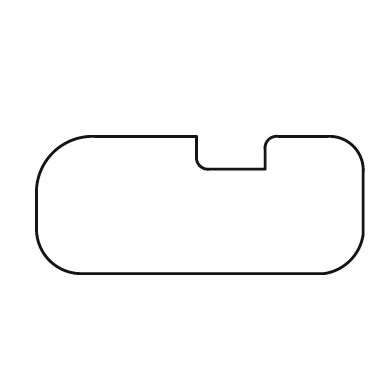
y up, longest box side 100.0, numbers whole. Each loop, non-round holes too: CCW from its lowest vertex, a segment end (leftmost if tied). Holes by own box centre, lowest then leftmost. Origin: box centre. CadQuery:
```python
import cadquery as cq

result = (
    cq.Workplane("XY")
    .moveTo(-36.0, -21.0)
    .lineTo(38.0, -21.0)
    .threePointArc((46.0, -17.0), (50.0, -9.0))
    .lineTo(50.0, 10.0)
    .threePointArc((47.0, 18.0), (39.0, 21.0))
    .lineTo(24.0, 21.0)
    .threePointArc((21.0, 20.0), (20.0, 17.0))
    .lineTo(20.0, 11.0)
    .lineTo(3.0, 11.0)
    .threePointArc((0.0, 12.0), (-1.0, 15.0))
    .lineTo(-1.0, 21.0)
    .lineTo(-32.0, 21.0)
    .threePointArc((-45.0, 16.0), (-50.0, 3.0))
    .lineTo(-50.0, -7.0)
    .threePointArc((-46.0, -17.0), (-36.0, -21.0))
    .close()
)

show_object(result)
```